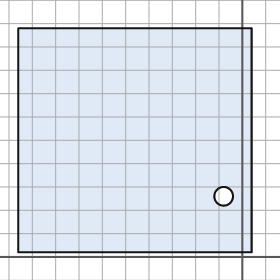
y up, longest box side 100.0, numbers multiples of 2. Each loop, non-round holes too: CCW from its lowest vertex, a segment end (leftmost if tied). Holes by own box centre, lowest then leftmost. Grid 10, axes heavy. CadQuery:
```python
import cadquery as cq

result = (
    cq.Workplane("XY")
    .moveTo(-96.0, 2.0)
    .lineTo(4.0, 2.0)
    .lineTo(4.0, 98.0)
    .lineTo(-96.0, 98.0)
    .close()
    .moveTo(-8.0, 26.0)
    .circle(4.0)
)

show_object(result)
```